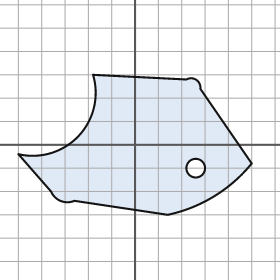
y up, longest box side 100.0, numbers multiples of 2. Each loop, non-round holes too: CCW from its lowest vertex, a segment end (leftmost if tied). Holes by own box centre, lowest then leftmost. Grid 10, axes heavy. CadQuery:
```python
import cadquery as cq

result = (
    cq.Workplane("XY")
    .moveTo(14.0, -30.0)
    .threePointArc((34.0, -22.0), (50.0, -8.0))
    .lineTo(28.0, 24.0)
    .threePointArc((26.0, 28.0), (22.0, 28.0))
    .lineTo(-18.0, 30.0)
    .threePointArc((-24.0, 4.0), (-50.0, -4.0))
    .lineTo(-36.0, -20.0)
    .threePointArc((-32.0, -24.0), (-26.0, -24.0))
    .close()
    .moveTo(26.0, -10.0)
    .circle(4.0)
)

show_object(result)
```